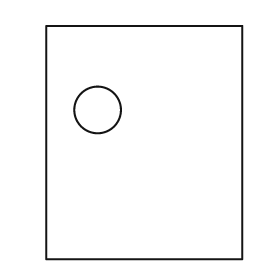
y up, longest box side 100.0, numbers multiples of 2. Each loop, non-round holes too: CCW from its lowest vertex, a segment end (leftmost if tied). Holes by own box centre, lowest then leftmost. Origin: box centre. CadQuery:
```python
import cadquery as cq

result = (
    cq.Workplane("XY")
    .moveTo(-42.0, -50.0)
    .lineTo(42.0, -50.0)
    .lineTo(42.0, 50.0)
    .lineTo(-42.0, 50.0)
    .close()
    .moveTo(-20.0, 14.0)
    .circle(10.0)
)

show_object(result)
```